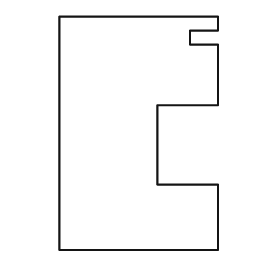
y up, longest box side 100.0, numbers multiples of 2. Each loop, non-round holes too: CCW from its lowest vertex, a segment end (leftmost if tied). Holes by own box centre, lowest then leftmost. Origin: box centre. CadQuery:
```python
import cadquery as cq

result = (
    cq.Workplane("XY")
    .moveTo(-34.0, -50.0)
    .lineTo(34.0, -50.0)
    .lineTo(34.0, -22.0)
    .lineTo(8.0, -22.0)
    .lineTo(8.0, 12.0)
    .lineTo(34.0, 12.0)
    .lineTo(34.0, 38.0)
    .lineTo(22.0, 38.0)
    .lineTo(22.0, 44.0)
    .lineTo(34.0, 44.0)
    .lineTo(34.0, 50.0)
    .lineTo(-34.0, 50.0)
    .close()
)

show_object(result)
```